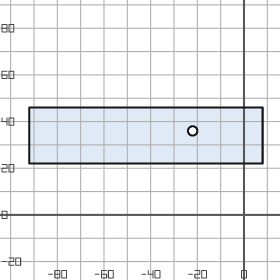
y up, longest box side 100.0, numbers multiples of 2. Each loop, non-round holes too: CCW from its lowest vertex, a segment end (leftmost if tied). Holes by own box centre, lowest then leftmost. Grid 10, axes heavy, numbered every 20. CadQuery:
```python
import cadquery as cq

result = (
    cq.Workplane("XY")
    .moveTo(-92.0, 22.0)
    .lineTo(8.0, 22.0)
    .lineTo(8.0, 46.0)
    .lineTo(-92.0, 46.0)
    .close()
    .moveTo(-22.0, 36.0)
    .circle(2.0)
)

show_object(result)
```